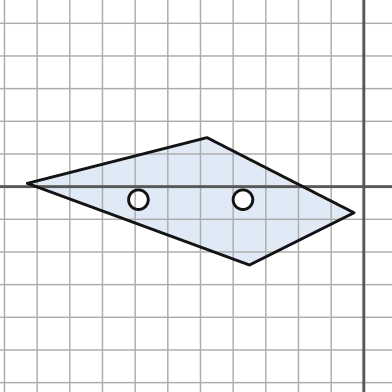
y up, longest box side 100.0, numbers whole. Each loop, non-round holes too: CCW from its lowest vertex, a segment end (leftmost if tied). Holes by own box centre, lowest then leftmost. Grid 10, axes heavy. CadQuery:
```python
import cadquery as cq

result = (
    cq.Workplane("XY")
    .moveTo(-35.0, -24.0)
    .lineTo(-3.0, -8.0)
    .lineTo(-48.0, 15.0)
    .lineTo(-103.0, 1.0)
    .close()
    .moveTo(-69.0, -4.0)
    .circle(3.0)
    .moveTo(-37.0, -4.0)
    .circle(3.0)
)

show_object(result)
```